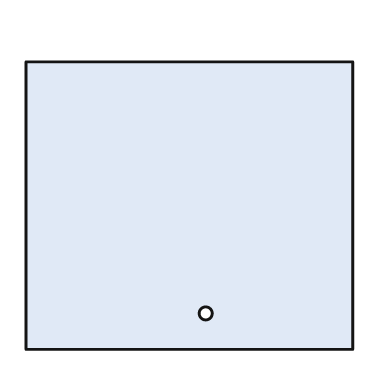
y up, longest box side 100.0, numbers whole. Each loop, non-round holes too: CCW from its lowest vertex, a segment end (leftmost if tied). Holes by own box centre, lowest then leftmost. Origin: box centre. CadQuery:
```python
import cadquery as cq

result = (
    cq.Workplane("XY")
    .moveTo(-50.0, -44.0)
    .lineTo(50.0, -44.0)
    .lineTo(50.0, 44.0)
    .lineTo(-50.0, 44.0)
    .close()
    .moveTo(5.0, -33.0)
    .circle(2.0)
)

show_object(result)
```